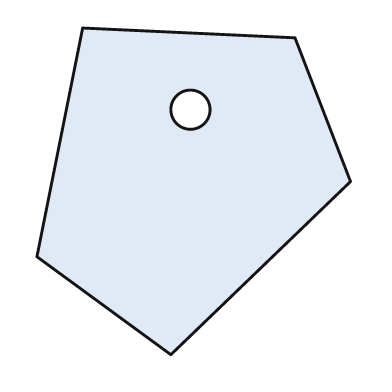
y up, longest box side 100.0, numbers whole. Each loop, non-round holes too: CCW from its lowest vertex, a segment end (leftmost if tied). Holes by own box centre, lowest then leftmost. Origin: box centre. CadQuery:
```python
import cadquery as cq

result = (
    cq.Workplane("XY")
    .moveTo(-7.0, -50.0)
    .lineTo(48.0, 3.0)
    .lineTo(31.0, 47.0)
    .lineTo(-34.0, 50.0)
    .lineTo(-48.0, -20.0)
    .close()
    .moveTo(-1.0, 25.0)
    .circle(6.0)
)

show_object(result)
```